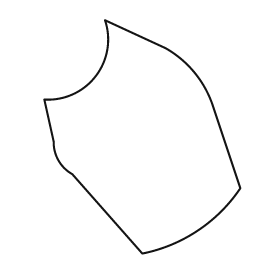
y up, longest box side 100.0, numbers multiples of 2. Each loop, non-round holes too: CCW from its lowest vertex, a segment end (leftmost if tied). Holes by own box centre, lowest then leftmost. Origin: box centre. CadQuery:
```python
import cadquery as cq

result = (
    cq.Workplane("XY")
    .moveTo(0.0, -50.0)
    .threePointArc((24.0, -40.0), (42.0, -22.0))
    .lineTo(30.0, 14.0)
    .threePointArc((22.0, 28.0), (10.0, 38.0))
    .lineTo(-16.0, 50.0)
    .threePointArc((-20.0, 26.0), (-42.0, 16.0))
    .lineTo(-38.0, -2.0)
    .threePointArc((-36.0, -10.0), (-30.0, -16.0))
    .close()
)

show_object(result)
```